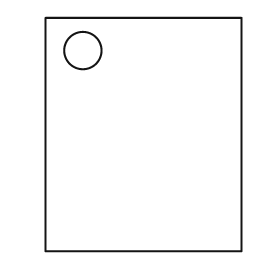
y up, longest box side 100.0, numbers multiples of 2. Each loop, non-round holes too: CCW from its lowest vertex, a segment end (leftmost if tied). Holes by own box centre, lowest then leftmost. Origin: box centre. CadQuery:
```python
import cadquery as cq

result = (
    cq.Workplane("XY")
    .moveTo(-42.0, -50.0)
    .lineTo(42.0, -50.0)
    .lineTo(42.0, 50.0)
    .lineTo(-42.0, 50.0)
    .close()
    .moveTo(-26.0, 36.0)
    .circle(8.0)
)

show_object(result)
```